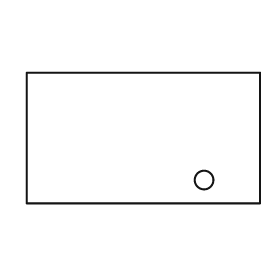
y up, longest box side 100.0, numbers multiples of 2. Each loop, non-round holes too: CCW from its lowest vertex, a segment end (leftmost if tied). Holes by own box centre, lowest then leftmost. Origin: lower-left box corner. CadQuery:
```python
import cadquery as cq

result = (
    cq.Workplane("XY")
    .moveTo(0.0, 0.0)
    .lineTo(100.0, 0.0)
    .lineTo(100.0, 56.0)
    .lineTo(0.0, 56.0)
    .close()
    .moveTo(76.0, 10.0)
    .circle(4.0)
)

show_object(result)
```